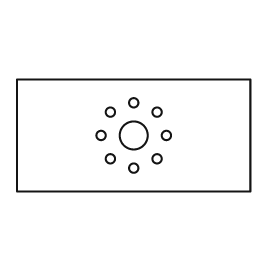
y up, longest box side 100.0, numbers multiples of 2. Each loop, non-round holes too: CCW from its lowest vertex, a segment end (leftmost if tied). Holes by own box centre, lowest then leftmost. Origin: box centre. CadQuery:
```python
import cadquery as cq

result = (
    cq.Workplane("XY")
    .moveTo(-50.0, -24.0)
    .lineTo(50.0, -24.0)
    .lineTo(50.0, 24.0)
    .lineTo(-50.0, 24.0)
    .close()
    .moveTo(0.0, -14.0)
    .circle(2.0)
    .moveTo(-10.0, -10.0)
    .circle(2.0)
    .moveTo(10.0, -10.0)
    .circle(2.0)
    .moveTo(-14.0, 0.0)
    .circle(2.0)
    .moveTo(0.0, 0.0)
    .circle(6.0)
    .moveTo(14.0, 0.0)
    .circle(2.0)
    .moveTo(-10.0, 10.0)
    .circle(2.0)
    .moveTo(10.0, 10.0)
    .circle(2.0)
    .moveTo(0.0, 14.0)
    .circle(2.0)
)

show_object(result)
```